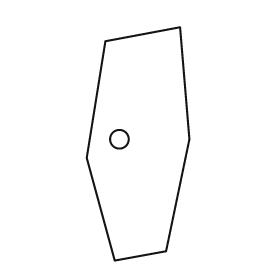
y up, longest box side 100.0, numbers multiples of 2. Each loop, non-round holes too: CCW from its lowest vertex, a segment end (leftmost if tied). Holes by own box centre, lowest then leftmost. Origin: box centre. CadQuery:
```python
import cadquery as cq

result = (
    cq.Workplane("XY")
    .moveTo(-10.0, -50.0)
    .lineTo(12.0, -46.0)
    .lineTo(22.0, 2.0)
    .lineTo(18.0, 50.0)
    .lineTo(-14.0, 44.0)
    .lineTo(-22.0, -6.0)
    .close()
    .moveTo(-8.0, 2.0)
    .circle(4.0)
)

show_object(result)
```